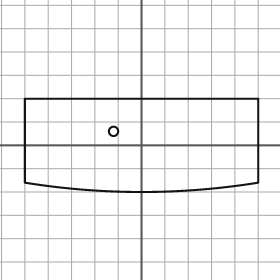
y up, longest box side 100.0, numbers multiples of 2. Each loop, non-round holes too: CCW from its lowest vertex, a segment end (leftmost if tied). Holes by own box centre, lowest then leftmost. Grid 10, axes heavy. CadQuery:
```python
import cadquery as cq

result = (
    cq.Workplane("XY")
    .moveTo(-50.0, -16.0)
    .threePointArc((0.0, -20.0), (50.0, -16.0))
    .lineTo(50.0, 20.0)
    .lineTo(-50.0, 20.0)
    .close()
    .moveTo(-12.0, 6.0)
    .circle(2.0)
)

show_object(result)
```